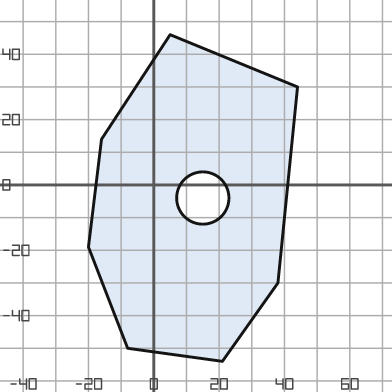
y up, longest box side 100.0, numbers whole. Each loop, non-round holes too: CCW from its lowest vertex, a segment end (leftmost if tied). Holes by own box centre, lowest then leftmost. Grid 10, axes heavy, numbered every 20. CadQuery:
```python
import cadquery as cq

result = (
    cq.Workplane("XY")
    .moveTo(21.0, -54.0)
    .lineTo(38.0, -30.0)
    .lineTo(44.0, 30.0)
    .lineTo(5.0, 46.0)
    .lineTo(-16.0, 14.0)
    .lineTo(-20.0, -19.0)
    .lineTo(-8.0, -50.0)
    .close()
    .moveTo(15.0, -4.0)
    .circle(8.0)
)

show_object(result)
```